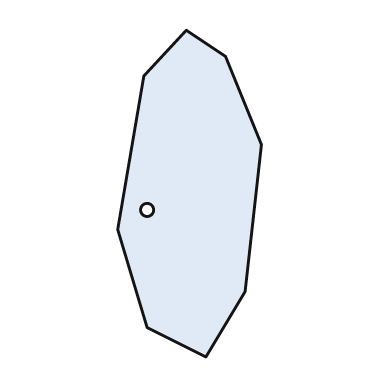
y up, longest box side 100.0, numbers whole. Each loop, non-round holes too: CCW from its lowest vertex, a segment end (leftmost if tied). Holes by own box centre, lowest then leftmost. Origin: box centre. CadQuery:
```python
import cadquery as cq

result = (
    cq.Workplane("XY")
    .moveTo(5.0, -50.0)
    .lineTo(17.0, -30.0)
    .lineTo(22.0, 15.0)
    .lineTo(11.0, 42.0)
    .lineTo(-1.0, 50.0)
    .lineTo(-14.0, 36.0)
    .lineTo(-22.0, -11.0)
    .lineTo(-13.0, -41.0)
    .close()
    .moveTo(-13.0, -5.0)
    .circle(2.0)
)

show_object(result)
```